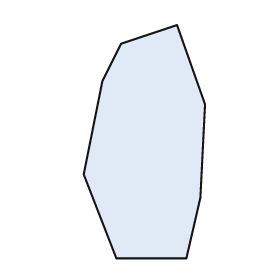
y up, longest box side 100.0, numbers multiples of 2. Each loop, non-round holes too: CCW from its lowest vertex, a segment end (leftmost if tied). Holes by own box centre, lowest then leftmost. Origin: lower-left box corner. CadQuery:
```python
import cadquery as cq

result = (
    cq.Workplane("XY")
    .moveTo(14.0, 0.0)
    .lineTo(44.0, 0.0)
    .lineTo(50.0, 26.0)
    .lineTo(52.0, 66.0)
    .lineTo(40.0, 100.0)
    .lineTo(16.0, 92.0)
    .lineTo(8.0, 76.0)
    .lineTo(0.0, 36.0)
    .close()
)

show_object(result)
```